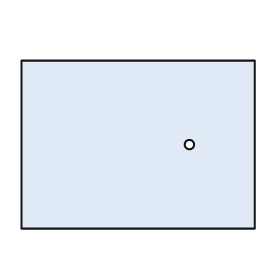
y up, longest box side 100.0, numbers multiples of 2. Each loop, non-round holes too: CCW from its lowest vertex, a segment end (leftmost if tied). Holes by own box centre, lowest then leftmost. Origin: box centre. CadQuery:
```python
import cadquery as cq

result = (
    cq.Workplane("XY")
    .moveTo(-50.0, -36.0)
    .lineTo(50.0, -36.0)
    .lineTo(50.0, 36.0)
    .lineTo(-50.0, 36.0)
    .close()
    .moveTo(22.0, 0.0)
    .circle(2.0)
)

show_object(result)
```